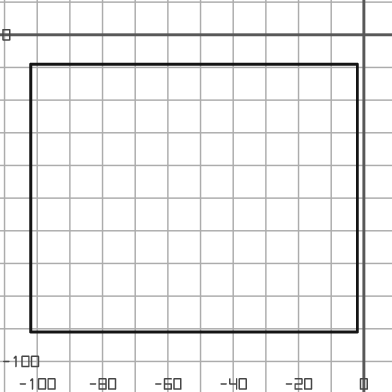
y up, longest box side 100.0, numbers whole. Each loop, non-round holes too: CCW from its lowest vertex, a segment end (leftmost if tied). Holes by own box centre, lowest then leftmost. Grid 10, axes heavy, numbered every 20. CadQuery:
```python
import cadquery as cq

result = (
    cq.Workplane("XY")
    .moveTo(-102.0, -91.0)
    .lineTo(-2.0, -91.0)
    .lineTo(-2.0, -9.0)
    .lineTo(-102.0, -9.0)
    .close()
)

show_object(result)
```